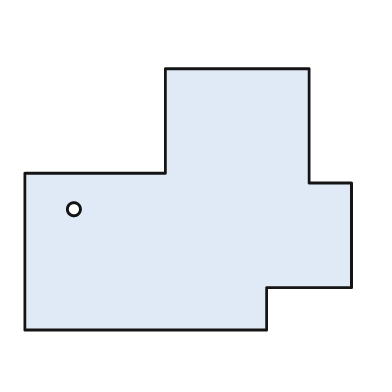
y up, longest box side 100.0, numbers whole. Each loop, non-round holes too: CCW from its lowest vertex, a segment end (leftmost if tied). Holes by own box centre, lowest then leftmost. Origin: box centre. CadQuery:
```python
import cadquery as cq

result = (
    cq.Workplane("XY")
    .moveTo(-50.0, -40.0)
    .lineTo(24.0, -40.0)
    .lineTo(24.0, -27.0)
    .lineTo(50.0, -27.0)
    .lineTo(50.0, 5.0)
    .lineTo(37.0, 5.0)
    .lineTo(37.0, 40.0)
    .lineTo(-7.0, 40.0)
    .lineTo(-7.0, 8.0)
    .lineTo(-50.0, 8.0)
    .close()
    .moveTo(-35.0, -3.0)
    .circle(2.0)
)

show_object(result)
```